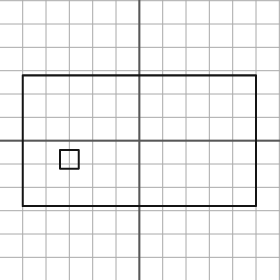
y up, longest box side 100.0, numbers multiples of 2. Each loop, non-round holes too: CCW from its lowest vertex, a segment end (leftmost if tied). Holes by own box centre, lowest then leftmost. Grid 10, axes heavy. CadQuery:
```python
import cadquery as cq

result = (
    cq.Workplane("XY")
    .moveTo(-50.0, -28.0)
    .lineTo(50.0, -28.0)
    .lineTo(50.0, 28.0)
    .lineTo(-50.0, 28.0)
    .close()
    .moveTo(-34.0, -12.0)
    .lineTo(-26.0, -12.0)
    .lineTo(-26.0, -4.0)
    .lineTo(-34.0, -4.0)
    .close()
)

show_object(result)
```